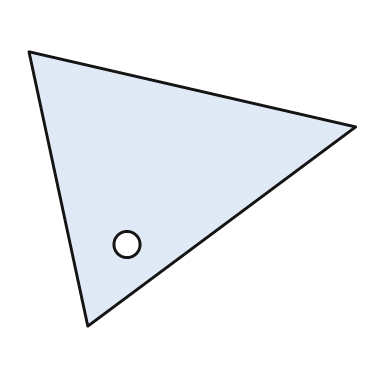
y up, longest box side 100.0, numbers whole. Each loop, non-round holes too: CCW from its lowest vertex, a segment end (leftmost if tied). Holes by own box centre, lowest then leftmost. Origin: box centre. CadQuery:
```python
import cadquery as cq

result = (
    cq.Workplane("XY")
    .moveTo(-32.0, -42.0)
    .lineTo(50.0, 19.0)
    .lineTo(-50.0, 42.0)
    .close()
    .moveTo(-20.0, -17.0)
    .circle(4.0)
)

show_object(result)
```